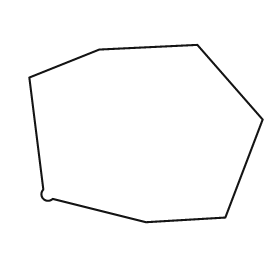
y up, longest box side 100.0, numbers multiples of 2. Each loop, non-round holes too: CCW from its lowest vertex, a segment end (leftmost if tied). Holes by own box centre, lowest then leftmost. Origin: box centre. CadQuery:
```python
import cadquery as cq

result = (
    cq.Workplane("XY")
    .moveTo(0.0, -38.0)
    .lineTo(34.0, -36.0)
    .lineTo(50.0, 6.0)
    .lineTo(22.0, 38.0)
    .lineTo(-20.0, 36.0)
    .lineTo(-50.0, 24.0)
    .lineTo(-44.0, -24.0)
    .threePointArc((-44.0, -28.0), (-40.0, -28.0))
    .close()
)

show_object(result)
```